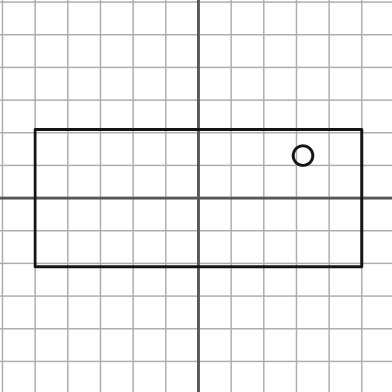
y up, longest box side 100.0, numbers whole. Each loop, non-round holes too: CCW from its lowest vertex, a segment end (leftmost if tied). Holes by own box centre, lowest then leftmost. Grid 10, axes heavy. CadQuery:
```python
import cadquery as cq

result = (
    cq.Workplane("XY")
    .moveTo(-50.0, -21.0)
    .lineTo(50.0, -21.0)
    .lineTo(50.0, 21.0)
    .lineTo(-50.0, 21.0)
    .close()
    .moveTo(32.0, 13.0)
    .circle(3.0)
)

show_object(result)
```